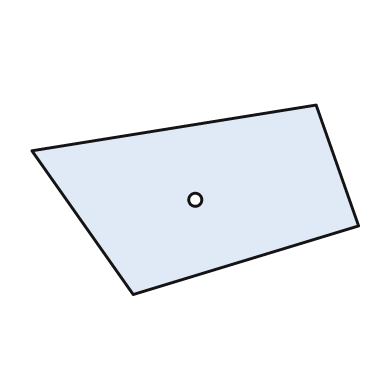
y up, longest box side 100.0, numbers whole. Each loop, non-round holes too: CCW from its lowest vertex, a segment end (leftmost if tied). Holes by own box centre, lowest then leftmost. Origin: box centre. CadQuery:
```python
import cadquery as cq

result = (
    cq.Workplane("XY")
    .moveTo(-19.0, -29.0)
    .lineTo(50.0, -8.0)
    .lineTo(37.0, 29.0)
    .lineTo(-50.0, 15.0)
    .close()
    .moveTo(0.0, 0.0)
    .circle(2.0)
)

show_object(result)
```